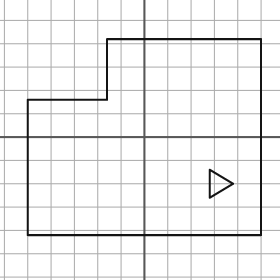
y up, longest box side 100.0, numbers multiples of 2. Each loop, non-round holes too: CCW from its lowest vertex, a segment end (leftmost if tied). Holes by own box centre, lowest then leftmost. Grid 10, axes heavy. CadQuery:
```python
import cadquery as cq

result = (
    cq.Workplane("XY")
    .moveTo(-50.0, -42.0)
    .lineTo(50.0, -42.0)
    .lineTo(50.0, 42.0)
    .lineTo(-16.0, 42.0)
    .lineTo(-16.0, 16.0)
    .lineTo(-50.0, 16.0)
    .close()
    .moveTo(28.0, -26.0)
    .lineTo(38.0, -20.0)
    .lineTo(28.0, -14.0)
    .close()
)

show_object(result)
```